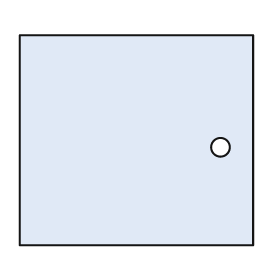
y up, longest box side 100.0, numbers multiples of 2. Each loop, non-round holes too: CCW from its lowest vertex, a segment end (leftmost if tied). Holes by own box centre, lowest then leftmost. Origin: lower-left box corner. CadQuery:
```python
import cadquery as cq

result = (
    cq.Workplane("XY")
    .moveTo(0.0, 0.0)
    .lineTo(100.0, 0.0)
    .lineTo(100.0, 90.0)
    .lineTo(0.0, 90.0)
    .close()
    .moveTo(86.0, 42.0)
    .circle(4.0)
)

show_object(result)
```